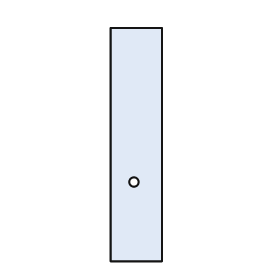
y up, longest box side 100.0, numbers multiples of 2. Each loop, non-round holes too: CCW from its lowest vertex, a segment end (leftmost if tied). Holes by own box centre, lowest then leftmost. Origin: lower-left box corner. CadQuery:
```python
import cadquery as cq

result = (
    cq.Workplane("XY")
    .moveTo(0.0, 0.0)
    .lineTo(22.0, 0.0)
    .lineTo(22.0, 100.0)
    .lineTo(0.0, 100.0)
    .close()
    .moveTo(10.0, 34.0)
    .circle(2.0)
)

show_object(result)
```